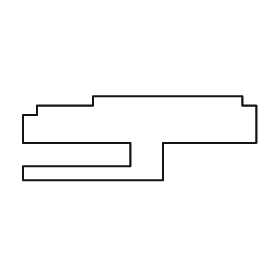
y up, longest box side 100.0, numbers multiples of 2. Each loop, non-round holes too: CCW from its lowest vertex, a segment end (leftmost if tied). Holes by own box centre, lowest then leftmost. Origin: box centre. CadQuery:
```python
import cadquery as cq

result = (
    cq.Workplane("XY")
    .moveTo(-50.0, -18.0)
    .lineTo(10.0, -18.0)
    .lineTo(10.0, -2.0)
    .lineTo(50.0, -2.0)
    .lineTo(50.0, 14.0)
    .lineTo(44.0, 14.0)
    .lineTo(44.0, 18.0)
    .lineTo(-20.0, 18.0)
    .lineTo(-20.0, 14.0)
    .lineTo(-44.0, 14.0)
    .lineTo(-44.0, 10.0)
    .lineTo(-50.0, 10.0)
    .lineTo(-50.0, -2.0)
    .lineTo(-4.0, -2.0)
    .lineTo(-4.0, -12.0)
    .lineTo(-50.0, -12.0)
    .close()
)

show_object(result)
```